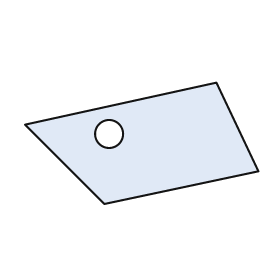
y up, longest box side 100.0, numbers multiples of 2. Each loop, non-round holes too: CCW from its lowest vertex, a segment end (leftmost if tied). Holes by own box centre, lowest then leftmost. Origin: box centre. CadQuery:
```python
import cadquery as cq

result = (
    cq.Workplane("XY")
    .moveTo(-16.0, -26.0)
    .lineTo(50.0, -12.0)
    .lineTo(32.0, 26.0)
    .lineTo(-50.0, 8.0)
    .close()
    .moveTo(-14.0, 4.0)
    .circle(6.0)
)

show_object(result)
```